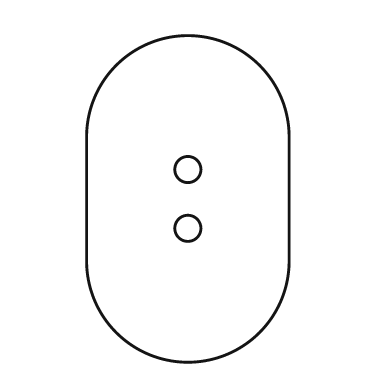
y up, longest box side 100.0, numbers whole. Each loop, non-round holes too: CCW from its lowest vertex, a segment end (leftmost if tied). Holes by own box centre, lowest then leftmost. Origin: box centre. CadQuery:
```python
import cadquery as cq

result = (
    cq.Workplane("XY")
    .moveTo(-31.0, -19.0)
    .threePointArc((0.0, -50.0), (31.0, -19.0))
    .lineTo(31.0, 19.0)
    .threePointArc((0.0, 50.0), (-31.0, 19.0))
    .close()
    .moveTo(0.0, -9.0)
    .circle(4.0)
    .moveTo(0.0, 9.0)
    .circle(4.0)
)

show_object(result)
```